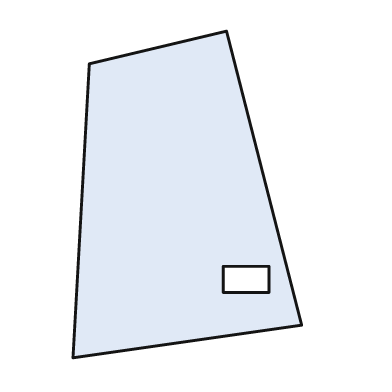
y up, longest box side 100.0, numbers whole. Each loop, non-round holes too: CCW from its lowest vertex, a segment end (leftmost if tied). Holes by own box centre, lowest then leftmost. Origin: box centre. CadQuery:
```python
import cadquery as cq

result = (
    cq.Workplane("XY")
    .moveTo(-35.0, -50.0)
    .lineTo(35.0, -40.0)
    .lineTo(12.0, 50.0)
    .lineTo(-30.0, 40.0)
    .close()
    .moveTo(11.0, -30.0)
    .lineTo(25.0, -30.0)
    .lineTo(25.0, -22.0)
    .lineTo(11.0, -22.0)
    .close()
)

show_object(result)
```